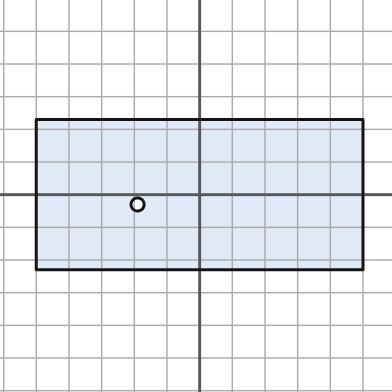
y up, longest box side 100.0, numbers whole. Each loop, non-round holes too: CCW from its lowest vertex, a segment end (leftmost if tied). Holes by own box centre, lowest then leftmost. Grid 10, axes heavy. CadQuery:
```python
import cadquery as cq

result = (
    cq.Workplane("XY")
    .moveTo(-50.0, -23.0)
    .lineTo(50.0, -23.0)
    .lineTo(50.0, 23.0)
    .lineTo(-50.0, 23.0)
    .close()
    .moveTo(-19.0, -3.0)
    .circle(2.0)
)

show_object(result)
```